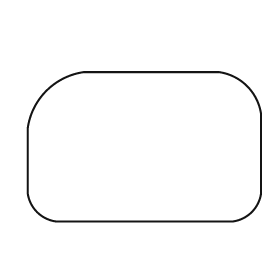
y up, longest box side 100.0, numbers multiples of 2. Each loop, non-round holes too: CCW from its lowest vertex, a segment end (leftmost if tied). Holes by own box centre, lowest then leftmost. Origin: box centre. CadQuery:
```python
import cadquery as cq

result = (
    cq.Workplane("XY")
    .moveTo(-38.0, -32.0)
    .lineTo(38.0, -32.0)
    .threePointArc((46.0, -28.0), (50.0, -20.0))
    .lineTo(50.0, 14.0)
    .threePointArc((44.0, 26.0), (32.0, 32.0))
    .lineTo(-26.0, 32.0)
    .threePointArc((-42.0, 24.0), (-50.0, 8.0))
    .lineTo(-50.0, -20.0)
    .threePointArc((-46.0, -28.0), (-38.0, -32.0))
    .close()
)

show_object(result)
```